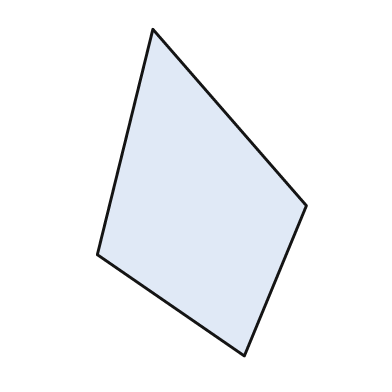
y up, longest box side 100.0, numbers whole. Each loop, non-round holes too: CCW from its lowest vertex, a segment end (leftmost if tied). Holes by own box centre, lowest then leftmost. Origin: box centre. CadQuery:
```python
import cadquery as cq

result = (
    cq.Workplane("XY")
    .moveTo(13.0, -50.0)
    .lineTo(32.0, -4.0)
    .lineTo(-15.0, 50.0)
    .lineTo(-32.0, -19.0)
    .close()
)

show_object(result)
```